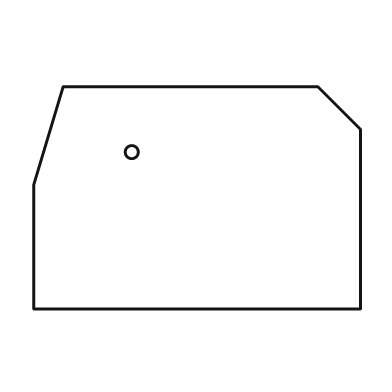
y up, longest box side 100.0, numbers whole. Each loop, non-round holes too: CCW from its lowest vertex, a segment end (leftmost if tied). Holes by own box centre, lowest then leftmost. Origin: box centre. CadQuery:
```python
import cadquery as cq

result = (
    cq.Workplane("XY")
    .moveTo(-50.0, -34.0)
    .lineTo(50.0, -34.0)
    .lineTo(50.0, 21.0)
    .lineTo(37.0, 34.0)
    .lineTo(-41.0, 34.0)
    .lineTo(-50.0, 4.0)
    .close()
    .moveTo(-20.0, 14.0)
    .circle(2.0)
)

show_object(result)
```